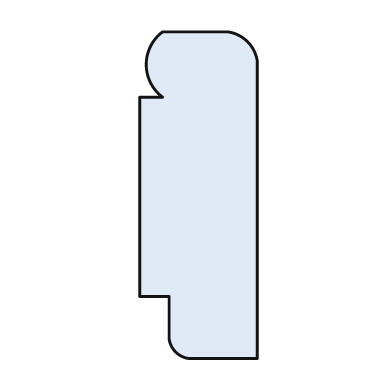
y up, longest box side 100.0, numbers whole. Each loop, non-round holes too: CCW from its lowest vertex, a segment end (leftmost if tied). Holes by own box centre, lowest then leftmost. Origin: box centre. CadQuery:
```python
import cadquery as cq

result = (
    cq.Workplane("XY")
    .moveTo(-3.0, -50.0)
    .lineTo(18.0, -50.0)
    .lineTo(18.0, 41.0)
    .threePointArc((15.0, 47.0), (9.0, 50.0))
    .lineTo(-11.0, 50.0)
    .threePointArc((-16.0, 40.0), (-11.0, 30.0))
    .lineTo(-18.0, 30.0)
    .lineTo(-18.0, -31.0)
    .lineTo(-9.0, -31.0)
    .lineTo(-9.0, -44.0)
    .threePointArc((-7.0, -48.0), (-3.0, -50.0))
    .close()
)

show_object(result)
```